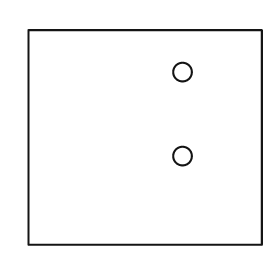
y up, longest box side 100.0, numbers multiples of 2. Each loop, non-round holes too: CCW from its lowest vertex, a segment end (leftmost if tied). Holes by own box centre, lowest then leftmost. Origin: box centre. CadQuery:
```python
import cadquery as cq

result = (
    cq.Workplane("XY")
    .moveTo(-50.0, -46.0)
    .lineTo(50.0, -46.0)
    .lineTo(50.0, 46.0)
    .lineTo(-50.0, 46.0)
    .close()
    .moveTo(16.0, -8.0)
    .circle(4.0)
    .moveTo(16.0, 28.0)
    .circle(4.0)
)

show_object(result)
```